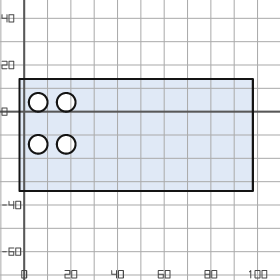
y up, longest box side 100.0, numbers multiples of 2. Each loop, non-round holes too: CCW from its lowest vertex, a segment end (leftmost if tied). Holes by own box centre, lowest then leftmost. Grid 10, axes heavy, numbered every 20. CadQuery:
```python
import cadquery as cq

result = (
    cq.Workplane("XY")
    .moveTo(-2.0, -34.0)
    .lineTo(98.0, -34.0)
    .lineTo(98.0, 14.0)
    .lineTo(-2.0, 14.0)
    .close()
    .moveTo(6.0, -14.0)
    .circle(4.0)
    .moveTo(18.0, -14.0)
    .circle(4.0)
    .moveTo(6.0, 4.0)
    .circle(4.0)
    .moveTo(18.0, 4.0)
    .circle(4.0)
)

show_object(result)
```